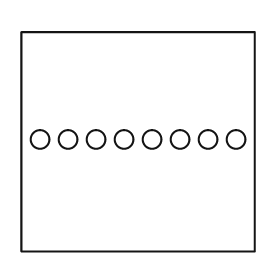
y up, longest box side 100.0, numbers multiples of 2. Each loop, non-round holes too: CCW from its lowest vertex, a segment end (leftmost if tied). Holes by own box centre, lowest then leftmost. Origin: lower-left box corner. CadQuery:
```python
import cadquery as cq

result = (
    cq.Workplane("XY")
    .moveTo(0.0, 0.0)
    .lineTo(100.0, 0.0)
    .lineTo(100.0, 94.0)
    .lineTo(0.0, 94.0)
    .close()
    .moveTo(8.0, 48.0)
    .circle(4.0)
    .moveTo(20.0, 48.0)
    .circle(4.0)
    .moveTo(32.0, 48.0)
    .circle(4.0)
    .moveTo(44.0, 48.0)
    .circle(4.0)
    .moveTo(56.0, 48.0)
    .circle(4.0)
    .moveTo(68.0, 48.0)
    .circle(4.0)
    .moveTo(80.0, 48.0)
    .circle(4.0)
    .moveTo(92.0, 48.0)
    .circle(4.0)
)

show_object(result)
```